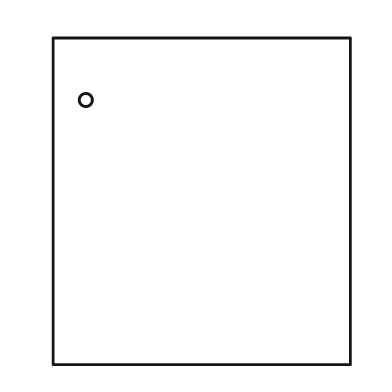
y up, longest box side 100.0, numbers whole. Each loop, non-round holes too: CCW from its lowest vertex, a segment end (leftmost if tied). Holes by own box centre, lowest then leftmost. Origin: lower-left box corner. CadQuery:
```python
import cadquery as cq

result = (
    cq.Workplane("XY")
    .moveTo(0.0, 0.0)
    .lineTo(91.0, 0.0)
    .lineTo(91.0, 100.0)
    .lineTo(0.0, 100.0)
    .close()
    .moveTo(10.0, 81.0)
    .circle(2.0)
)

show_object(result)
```